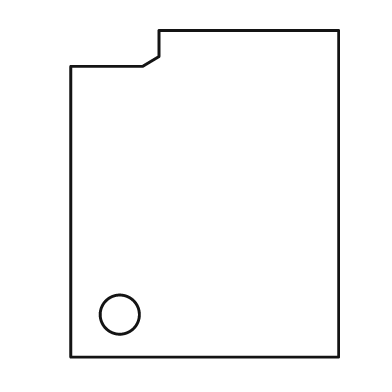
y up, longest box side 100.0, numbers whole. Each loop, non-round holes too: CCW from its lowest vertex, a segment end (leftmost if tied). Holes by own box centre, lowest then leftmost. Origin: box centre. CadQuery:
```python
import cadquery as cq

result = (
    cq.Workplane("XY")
    .moveTo(-41.0, -50.0)
    .lineTo(41.0, -50.0)
    .lineTo(41.0, 50.0)
    .lineTo(-14.0, 50.0)
    .lineTo(-14.0, 42.0)
    .lineTo(-19.0, 39.0)
    .lineTo(-41.0, 39.0)
    .close()
    .moveTo(-26.0, -37.0)
    .circle(6.0)
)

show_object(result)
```